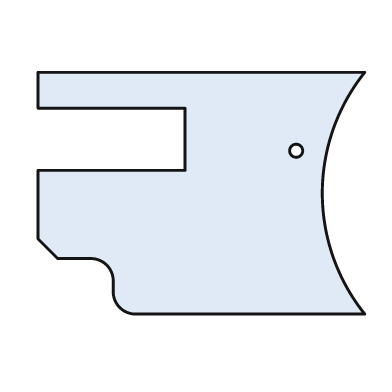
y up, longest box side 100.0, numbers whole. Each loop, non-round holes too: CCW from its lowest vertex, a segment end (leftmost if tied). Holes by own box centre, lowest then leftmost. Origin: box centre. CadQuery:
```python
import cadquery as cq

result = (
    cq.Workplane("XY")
    .moveTo(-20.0, -37.0)
    .lineTo(50.0, -37.0)
    .threePointArc((37.0, 0.0), (50.0, 37.0))
    .lineTo(-50.0, 37.0)
    .lineTo(-50.0, 26.0)
    .lineTo(-5.0, 26.0)
    .lineTo(-5.0, 7.0)
    .lineTo(-50.0, 7.0)
    .lineTo(-50.0, -14.0)
    .lineTo(-44.0, -20.0)
    .lineTo(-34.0, -20.0)
    .threePointArc((-29.0, -22.0), (-27.0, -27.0))
    .lineTo(-27.0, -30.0)
    .threePointArc((-25.0, -35.0), (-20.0, -37.0))
    .close()
    .moveTo(29.0, 13.0)
    .circle(2.0)
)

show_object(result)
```